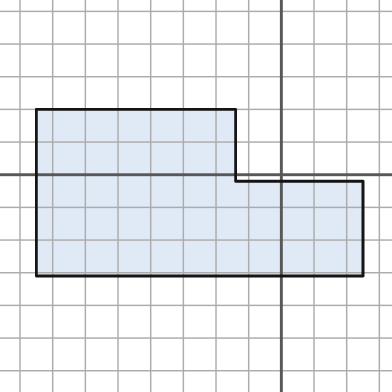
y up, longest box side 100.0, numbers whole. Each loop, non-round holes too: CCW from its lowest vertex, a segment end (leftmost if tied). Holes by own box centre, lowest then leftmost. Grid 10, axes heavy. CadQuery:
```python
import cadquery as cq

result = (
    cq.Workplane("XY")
    .moveTo(-75.0, -31.0)
    .lineTo(25.0, -31.0)
    .lineTo(25.0, -2.0)
    .lineTo(-14.0, -2.0)
    .lineTo(-14.0, 20.0)
    .lineTo(-75.0, 20.0)
    .close()
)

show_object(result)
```